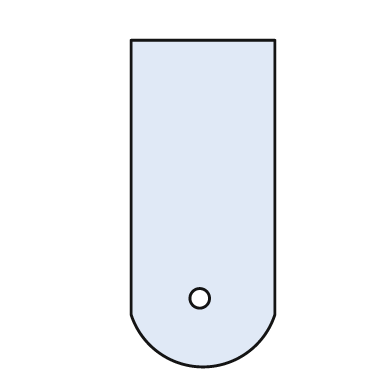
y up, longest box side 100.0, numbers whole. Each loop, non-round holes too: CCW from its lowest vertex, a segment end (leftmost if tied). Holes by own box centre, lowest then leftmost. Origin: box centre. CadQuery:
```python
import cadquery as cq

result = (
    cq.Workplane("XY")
    .moveTo(-22.0, -34.0)
    .threePointArc((0.0, -50.0), (22.0, -34.0))
    .lineTo(22.0, 50.0)
    .lineTo(-22.0, 50.0)
    .close()
    .moveTo(-1.0, -29.0)
    .circle(3.0)
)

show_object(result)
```